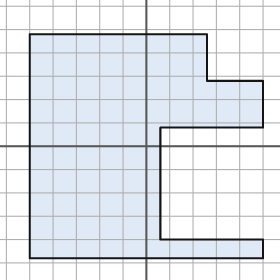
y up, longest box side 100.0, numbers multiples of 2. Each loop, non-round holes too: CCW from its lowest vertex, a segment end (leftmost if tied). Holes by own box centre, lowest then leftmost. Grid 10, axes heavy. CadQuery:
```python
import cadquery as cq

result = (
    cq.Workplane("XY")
    .moveTo(-50.0, -48.0)
    .lineTo(50.0, -48.0)
    .lineTo(50.0, -40.0)
    .lineTo(6.0, -40.0)
    .lineTo(6.0, 8.0)
    .lineTo(50.0, 8.0)
    .lineTo(50.0, 28.0)
    .lineTo(26.0, 28.0)
    .lineTo(26.0, 48.0)
    .lineTo(-50.0, 48.0)
    .close()
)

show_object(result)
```